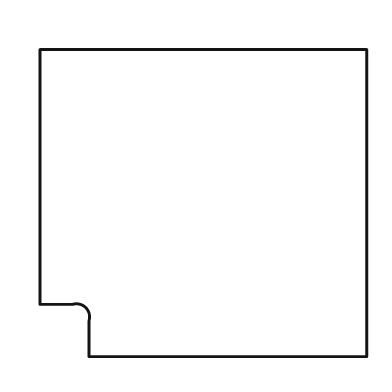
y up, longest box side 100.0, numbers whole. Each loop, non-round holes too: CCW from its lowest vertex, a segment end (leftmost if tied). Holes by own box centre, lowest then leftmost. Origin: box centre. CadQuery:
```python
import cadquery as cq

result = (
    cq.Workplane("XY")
    .moveTo(-35.0, -47.0)
    .lineTo(50.0, -47.0)
    .lineTo(50.0, 47.0)
    .lineTo(-50.0, 47.0)
    .lineTo(-50.0, -31.0)
    .lineTo(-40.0, -31.0)
    .threePointArc((-36.0, -32.0), (-35.0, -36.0))
    .close()
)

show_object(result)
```